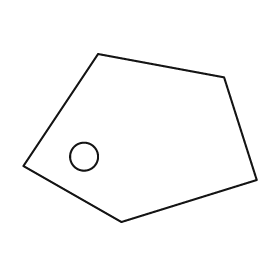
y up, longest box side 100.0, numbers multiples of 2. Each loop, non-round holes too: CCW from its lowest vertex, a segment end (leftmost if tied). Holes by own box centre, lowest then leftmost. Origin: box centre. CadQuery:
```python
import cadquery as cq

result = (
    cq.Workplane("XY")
    .moveTo(-8.0, -36.0)
    .lineTo(50.0, -18.0)
    .lineTo(36.0, 26.0)
    .lineTo(-18.0, 36.0)
    .lineTo(-50.0, -12.0)
    .close()
    .moveTo(-24.0, -8.0)
    .circle(6.0)
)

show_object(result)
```